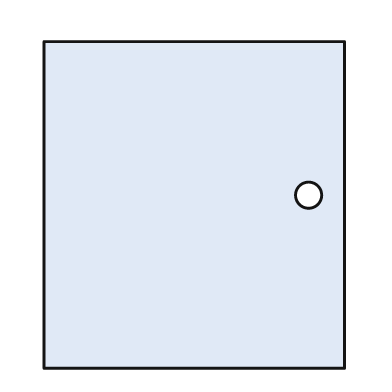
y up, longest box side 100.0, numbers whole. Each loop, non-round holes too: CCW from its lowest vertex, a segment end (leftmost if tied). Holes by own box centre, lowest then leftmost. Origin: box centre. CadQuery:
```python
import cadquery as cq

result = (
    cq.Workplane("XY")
    .moveTo(-46.0, -50.0)
    .lineTo(46.0, -50.0)
    .lineTo(46.0, 50.0)
    .lineTo(-46.0, 50.0)
    .close()
    .moveTo(35.0, 3.0)
    .circle(4.0)
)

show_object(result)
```